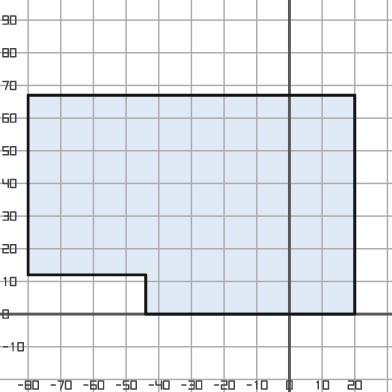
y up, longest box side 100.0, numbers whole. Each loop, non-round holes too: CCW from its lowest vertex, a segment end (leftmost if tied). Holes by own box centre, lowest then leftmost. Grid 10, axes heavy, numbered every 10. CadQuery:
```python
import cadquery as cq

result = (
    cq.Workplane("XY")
    .moveTo(-44.0, 0.0)
    .lineTo(20.0, 0.0)
    .lineTo(20.0, 67.0)
    .lineTo(-80.0, 67.0)
    .lineTo(-80.0, 12.0)
    .lineTo(-44.0, 12.0)
    .close()
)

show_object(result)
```